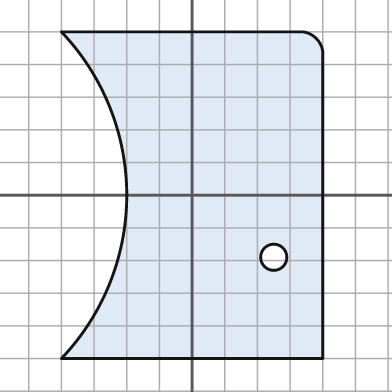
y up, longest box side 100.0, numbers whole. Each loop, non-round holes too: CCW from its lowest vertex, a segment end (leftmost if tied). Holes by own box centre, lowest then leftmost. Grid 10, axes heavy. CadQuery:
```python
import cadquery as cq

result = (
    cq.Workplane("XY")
    .moveTo(-40.0, -50.0)
    .lineTo(40.0, -50.0)
    .lineTo(40.0, 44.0)
    .threePointArc((38.0, 48.0), (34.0, 50.0))
    .lineTo(-40.0, 50.0)
    .threePointArc((-20.0, 0.0), (-40.0, -50.0))
    .close()
    .moveTo(25.0, -19.0)
    .circle(4.0)
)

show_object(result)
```